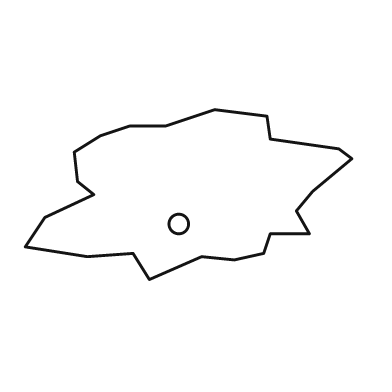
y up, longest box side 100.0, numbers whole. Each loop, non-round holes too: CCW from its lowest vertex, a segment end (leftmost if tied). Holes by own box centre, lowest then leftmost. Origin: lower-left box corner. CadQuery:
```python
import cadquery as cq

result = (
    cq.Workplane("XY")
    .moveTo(38.0, 0.0)
    .lineTo(54.0, 7.0)
    .lineTo(64.0, 6.0)
    .lineTo(73.0, 8.0)
    .lineTo(75.0, 14.0)
    .lineTo(87.0, 14.0)
    .lineTo(83.0, 21.0)
    .lineTo(88.0, 27.0)
    .lineTo(100.0, 37.0)
    .lineTo(96.0, 40.0)
    .lineTo(75.0, 43.0)
    .lineTo(74.0, 50.0)
    .lineTo(58.0, 52.0)
    .lineTo(43.0, 47.0)
    .lineTo(32.0, 47.0)
    .lineTo(23.0, 44.0)
    .lineTo(15.0, 39.0)
    .lineTo(16.0, 30.0)
    .lineTo(21.0, 26.0)
    .lineTo(6.0, 19.0)
    .lineTo(0.0, 10.0)
    .lineTo(19.0, 7.0)
    .lineTo(33.0, 8.0)
    .close()
    .moveTo(47.0, 17.0)
    .circle(3.0)
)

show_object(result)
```